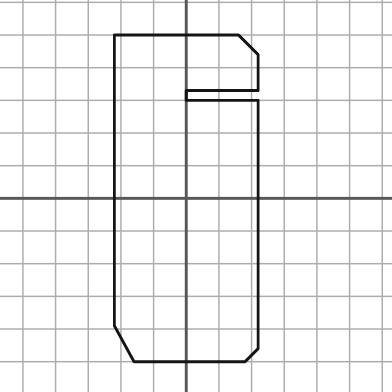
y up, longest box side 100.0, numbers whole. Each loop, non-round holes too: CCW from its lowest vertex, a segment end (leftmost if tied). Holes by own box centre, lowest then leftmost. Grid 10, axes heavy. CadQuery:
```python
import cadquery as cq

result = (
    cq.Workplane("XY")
    .moveTo(-16.0, -50.0)
    .lineTo(18.0, -50.0)
    .lineTo(22.0, -46.0)
    .lineTo(22.0, 30.0)
    .lineTo(0.0, 30.0)
    .lineTo(0.0, 33.0)
    .lineTo(22.0, 33.0)
    .lineTo(22.0, 44.0)
    .lineTo(16.0, 50.0)
    .lineTo(-22.0, 50.0)
    .lineTo(-22.0, -39.0)
    .close()
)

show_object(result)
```